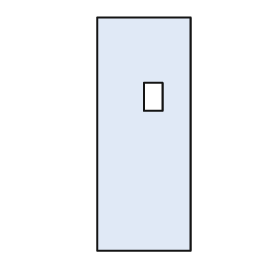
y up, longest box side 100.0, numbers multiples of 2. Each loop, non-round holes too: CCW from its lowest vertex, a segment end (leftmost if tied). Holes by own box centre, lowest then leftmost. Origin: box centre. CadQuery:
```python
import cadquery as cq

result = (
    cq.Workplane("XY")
    .moveTo(-20.0, -50.0)
    .lineTo(20.0, -50.0)
    .lineTo(20.0, 50.0)
    .lineTo(-20.0, 50.0)
    .close()
    .moveTo(0.0, 10.0)
    .lineTo(8.0, 10.0)
    .lineTo(8.0, 22.0)
    .lineTo(0.0, 22.0)
    .close()
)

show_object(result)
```